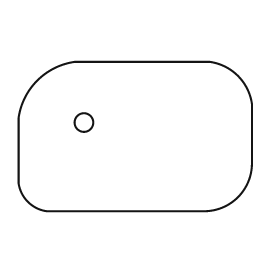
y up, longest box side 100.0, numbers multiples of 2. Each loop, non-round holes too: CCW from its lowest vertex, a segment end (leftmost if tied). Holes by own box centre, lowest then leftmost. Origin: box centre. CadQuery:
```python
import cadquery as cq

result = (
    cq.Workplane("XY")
    .moveTo(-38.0, -32.0)
    .lineTo(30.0, -32.0)
    .threePointArc((44.0, -26.0), (50.0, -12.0))
    .lineTo(50.0, 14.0)
    .threePointArc((44.0, 26.0), (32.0, 32.0))
    .lineTo(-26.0, 32.0)
    .threePointArc((-42.0, 24.0), (-50.0, 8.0))
    .lineTo(-50.0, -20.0)
    .threePointArc((-46.0, -28.0), (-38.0, -32.0))
    .close()
    .moveTo(-22.0, 6.0)
    .circle(4.0)
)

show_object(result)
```